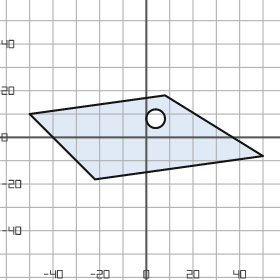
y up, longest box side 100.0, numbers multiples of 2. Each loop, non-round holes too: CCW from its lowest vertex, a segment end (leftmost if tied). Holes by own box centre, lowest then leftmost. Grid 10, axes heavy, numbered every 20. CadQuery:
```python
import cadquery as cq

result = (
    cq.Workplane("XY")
    .moveTo(-22.0, -18.0)
    .lineTo(50.0, -8.0)
    .lineTo(8.0, 18.0)
    .lineTo(-50.0, 10.0)
    .close()
    .moveTo(4.0, 8.0)
    .circle(4.0)
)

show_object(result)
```